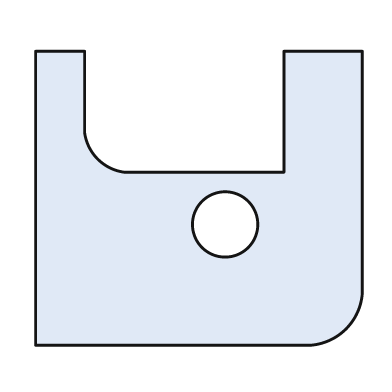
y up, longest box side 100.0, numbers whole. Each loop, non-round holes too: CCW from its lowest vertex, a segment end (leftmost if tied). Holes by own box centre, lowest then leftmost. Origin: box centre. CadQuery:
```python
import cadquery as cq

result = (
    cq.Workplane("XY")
    .moveTo(-50.0, -45.0)
    .lineTo(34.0, -45.0)
    .threePointArc((45.0, -40.0), (50.0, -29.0))
    .lineTo(50.0, 45.0)
    .lineTo(26.0, 45.0)
    .lineTo(26.0, 8.0)
    .lineTo(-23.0, 8.0)
    .threePointArc((-31.0, 12.0), (-35.0, 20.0))
    .lineTo(-35.0, 45.0)
    .lineTo(-50.0, 45.0)
    .close()
    .moveTo(8.0, -8.0)
    .circle(10.0)
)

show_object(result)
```